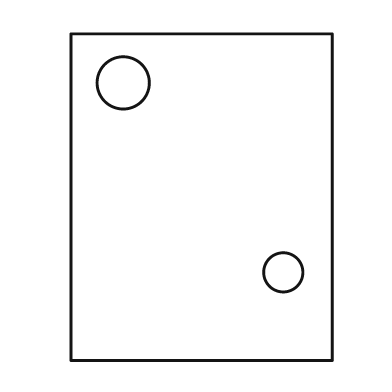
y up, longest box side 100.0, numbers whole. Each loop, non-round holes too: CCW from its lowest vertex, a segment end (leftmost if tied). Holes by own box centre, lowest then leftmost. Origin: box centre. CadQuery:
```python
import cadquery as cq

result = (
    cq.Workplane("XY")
    .moveTo(-40.0, -50.0)
    .lineTo(40.0, -50.0)
    .lineTo(40.0, 50.0)
    .lineTo(-40.0, 50.0)
    .close()
    .moveTo(25.0, -23.0)
    .circle(6.0)
    .moveTo(-24.0, 35.0)
    .circle(8.0)
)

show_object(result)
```